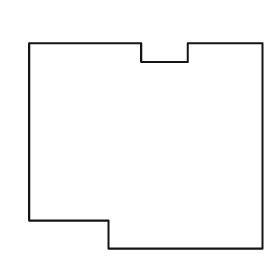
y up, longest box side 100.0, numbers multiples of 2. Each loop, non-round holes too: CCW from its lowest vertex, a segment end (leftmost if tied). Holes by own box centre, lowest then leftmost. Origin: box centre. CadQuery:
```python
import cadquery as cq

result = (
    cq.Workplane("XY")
    .moveTo(-16.0, -44.0)
    .lineTo(50.0, -44.0)
    .lineTo(50.0, 44.0)
    .lineTo(18.0, 44.0)
    .lineTo(18.0, 36.0)
    .lineTo(-2.0, 36.0)
    .lineTo(-2.0, 44.0)
    .lineTo(-50.0, 44.0)
    .lineTo(-50.0, -32.0)
    .lineTo(-16.0, -32.0)
    .close()
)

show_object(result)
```